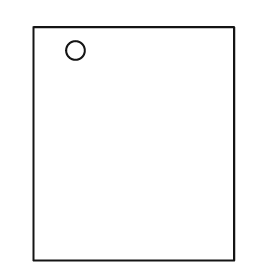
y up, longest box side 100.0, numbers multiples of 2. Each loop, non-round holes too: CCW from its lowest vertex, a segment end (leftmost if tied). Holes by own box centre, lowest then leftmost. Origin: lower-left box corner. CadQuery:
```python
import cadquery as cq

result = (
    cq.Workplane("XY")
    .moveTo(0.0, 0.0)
    .lineTo(86.0, 0.0)
    .lineTo(86.0, 100.0)
    .lineTo(0.0, 100.0)
    .close()
    .moveTo(18.0, 90.0)
    .circle(4.0)
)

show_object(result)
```